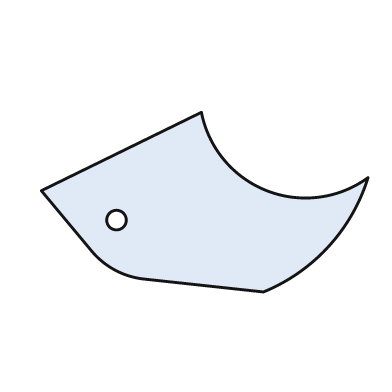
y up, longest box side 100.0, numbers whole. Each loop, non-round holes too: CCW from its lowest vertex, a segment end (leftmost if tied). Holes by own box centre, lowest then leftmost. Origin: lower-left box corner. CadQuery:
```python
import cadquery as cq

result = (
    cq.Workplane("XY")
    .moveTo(68.0, 0.0)
    .threePointArc((88.0, 14.0), (100.0, 35.0))
    .threePointArc((69.0, 31.0), (49.0, 55.0))
    .lineTo(0.0, 31.0)
    .lineTo(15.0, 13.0)
    .threePointArc((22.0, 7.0), (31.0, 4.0))
    .close()
    .moveTo(23.0, 22.0)
    .circle(3.0)
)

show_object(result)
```